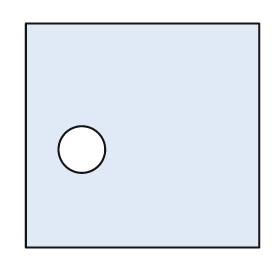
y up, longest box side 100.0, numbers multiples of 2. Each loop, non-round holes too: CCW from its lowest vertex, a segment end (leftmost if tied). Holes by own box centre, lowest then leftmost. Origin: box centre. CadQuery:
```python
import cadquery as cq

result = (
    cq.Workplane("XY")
    .moveTo(-50.0, -48.0)
    .lineTo(50.0, -48.0)
    .lineTo(50.0, 48.0)
    .lineTo(-50.0, 48.0)
    .close()
    .moveTo(-26.0, -6.0)
    .circle(10.0)
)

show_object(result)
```